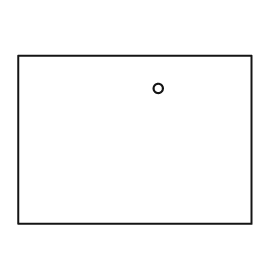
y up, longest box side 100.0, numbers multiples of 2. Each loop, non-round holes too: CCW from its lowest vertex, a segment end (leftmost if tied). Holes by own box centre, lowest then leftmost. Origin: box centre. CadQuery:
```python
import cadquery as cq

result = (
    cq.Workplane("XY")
    .moveTo(-50.0, -36.0)
    .lineTo(50.0, -36.0)
    .lineTo(50.0, 36.0)
    .lineTo(-50.0, 36.0)
    .close()
    .moveTo(10.0, 22.0)
    .circle(2.0)
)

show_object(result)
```